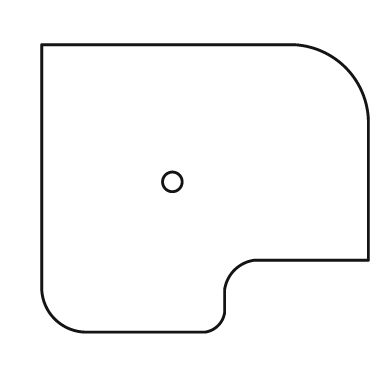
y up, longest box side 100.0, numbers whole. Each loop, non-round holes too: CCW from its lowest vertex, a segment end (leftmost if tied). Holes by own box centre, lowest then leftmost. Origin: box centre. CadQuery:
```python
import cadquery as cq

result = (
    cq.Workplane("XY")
    .moveTo(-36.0, -44.0)
    .lineTo(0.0, -44.0)
    .threePointArc((4.0, -42.0), (6.0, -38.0))
    .lineTo(6.0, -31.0)
    .threePointArc((9.0, -25.0), (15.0, -22.0))
    .lineTo(50.0, -22.0)
    .lineTo(50.0, 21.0)
    .threePointArc((43.0, 37.0), (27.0, 44.0))
    .lineTo(-50.0, 44.0)
    .lineTo(-50.0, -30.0)
    .threePointArc((-46.0, -40.0), (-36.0, -44.0))
    .close()
    .moveTo(-10.0, 2.0)
    .circle(3.0)
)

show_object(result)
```